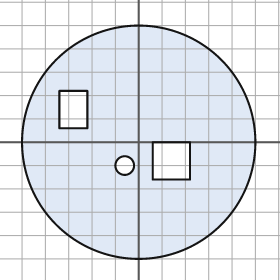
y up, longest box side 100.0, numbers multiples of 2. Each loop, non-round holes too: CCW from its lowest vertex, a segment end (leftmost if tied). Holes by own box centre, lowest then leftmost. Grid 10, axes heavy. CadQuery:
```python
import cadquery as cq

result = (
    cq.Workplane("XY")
    .moveTo(0.0, 0.0)
    .circle(50.0)
    .moveTo(-6.0, -10.0)
    .circle(4.0)
    .moveTo(6.0, -16.0)
    .lineTo(22.0, -16.0)
    .lineTo(22.0, 0.0)
    .lineTo(6.0, 0.0)
    .close()
    .moveTo(-34.0, 6.0)
    .lineTo(-22.0, 6.0)
    .lineTo(-22.0, 22.0)
    .lineTo(-34.0, 22.0)
    .close()
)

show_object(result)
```